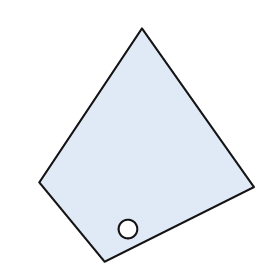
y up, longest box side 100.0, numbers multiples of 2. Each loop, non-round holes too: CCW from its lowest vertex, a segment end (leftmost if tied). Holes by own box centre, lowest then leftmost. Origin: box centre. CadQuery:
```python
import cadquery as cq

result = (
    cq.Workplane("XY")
    .moveTo(-18.0, -50.0)
    .lineTo(46.0, -18.0)
    .lineTo(-2.0, 50.0)
    .lineTo(-46.0, -16.0)
    .close()
    .moveTo(-8.0, -36.0)
    .circle(4.0)
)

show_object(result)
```